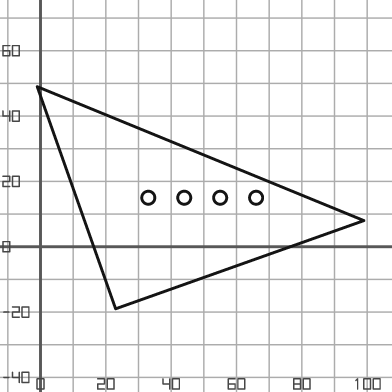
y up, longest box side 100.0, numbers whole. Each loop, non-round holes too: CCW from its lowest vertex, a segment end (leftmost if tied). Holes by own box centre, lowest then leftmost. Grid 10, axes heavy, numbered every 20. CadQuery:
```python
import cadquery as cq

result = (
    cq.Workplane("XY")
    .moveTo(23.0, -19.0)
    .lineTo(99.0, 8.0)
    .lineTo(-1.0, 49.0)
    .close()
    .moveTo(33.0, 15.0)
    .circle(2.0)
    .moveTo(44.0, 15.0)
    .circle(2.0)
    .moveTo(55.0, 15.0)
    .circle(2.0)
    .moveTo(66.0, 15.0)
    .circle(2.0)
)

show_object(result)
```